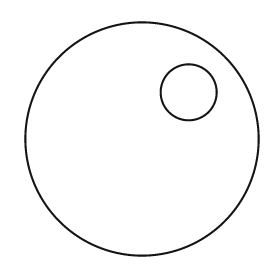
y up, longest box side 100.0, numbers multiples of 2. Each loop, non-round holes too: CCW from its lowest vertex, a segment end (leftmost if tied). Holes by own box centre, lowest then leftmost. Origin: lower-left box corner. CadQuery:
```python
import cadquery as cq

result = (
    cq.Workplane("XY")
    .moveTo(50.0, 50.0)
    .circle(50.0)
    .moveTo(70.0, 70.0)
    .circle(12.0)
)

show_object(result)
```